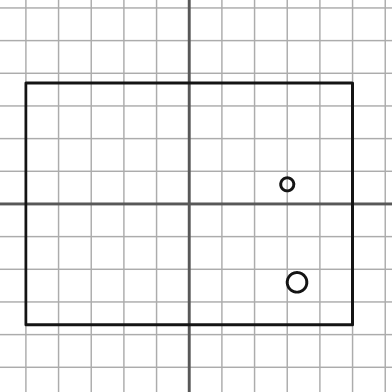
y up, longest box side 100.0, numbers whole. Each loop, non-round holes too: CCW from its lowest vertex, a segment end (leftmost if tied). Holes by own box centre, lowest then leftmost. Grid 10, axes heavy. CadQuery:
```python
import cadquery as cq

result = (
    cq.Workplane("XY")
    .moveTo(-50.0, -37.0)
    .lineTo(50.0, -37.0)
    .lineTo(50.0, 37.0)
    .lineTo(-50.0, 37.0)
    .close()
    .moveTo(33.0, -24.0)
    .circle(3.0)
    .moveTo(30.0, 6.0)
    .circle(2.0)
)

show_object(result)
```